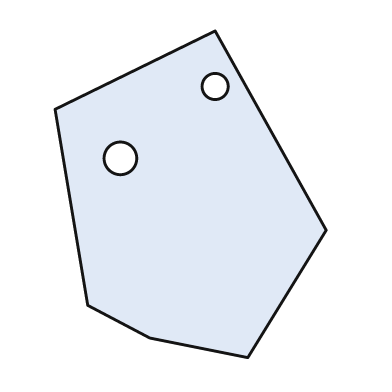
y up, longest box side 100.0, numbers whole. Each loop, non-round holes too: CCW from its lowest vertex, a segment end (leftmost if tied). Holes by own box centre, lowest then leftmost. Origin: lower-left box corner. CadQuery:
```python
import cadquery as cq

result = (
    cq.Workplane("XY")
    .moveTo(59.0, 0.0)
    .lineTo(83.0, 39.0)
    .lineTo(49.0, 100.0)
    .lineTo(0.0, 76.0)
    .lineTo(10.0, 16.0)
    .lineTo(29.0, 6.0)
    .close()
    .moveTo(20.0, 61.0)
    .circle(5.0)
    .moveTo(49.0, 83.0)
    .circle(4.0)
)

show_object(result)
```